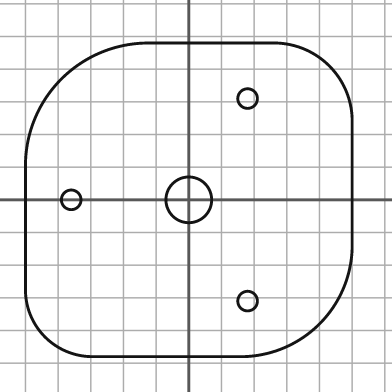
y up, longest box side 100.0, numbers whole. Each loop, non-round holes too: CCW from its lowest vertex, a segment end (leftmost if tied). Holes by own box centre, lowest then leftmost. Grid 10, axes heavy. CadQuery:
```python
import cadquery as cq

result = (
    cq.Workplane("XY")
    .moveTo(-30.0, -48.0)
    .lineTo(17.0, -48.0)
    .threePointArc((40.0, -38.0), (50.0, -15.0))
    .lineTo(50.0, 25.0)
    .threePointArc((43.0, 41.0), (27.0, 48.0))
    .lineTo(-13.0, 48.0)
    .threePointArc((-39.0, 37.0), (-50.0, 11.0))
    .lineTo(-50.0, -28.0)
    .threePointArc((-44.0, -42.0), (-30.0, -48.0))
    .close()
    .moveTo(18.0, -31.0)
    .circle(3.0)
    .moveTo(-36.0, 0.0)
    .circle(3.0)
    .moveTo(0.0, 0.0)
    .circle(7.0)
    .moveTo(18.0, 31.0)
    .circle(3.0)
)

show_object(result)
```